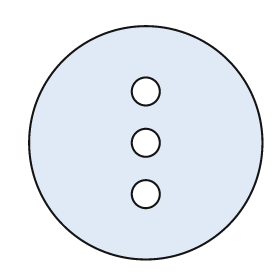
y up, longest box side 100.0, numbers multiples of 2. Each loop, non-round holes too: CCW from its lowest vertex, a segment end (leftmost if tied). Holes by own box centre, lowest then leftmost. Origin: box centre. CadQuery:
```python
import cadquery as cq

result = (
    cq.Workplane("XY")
    .moveTo(0.0, 0.0)
    .circle(50.0)
    .moveTo(0.0, -22.0)
    .circle(6.0)
    .moveTo(0.0, 0.0)
    .circle(6.0)
    .moveTo(0.0, 22.0)
    .circle(6.0)
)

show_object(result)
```